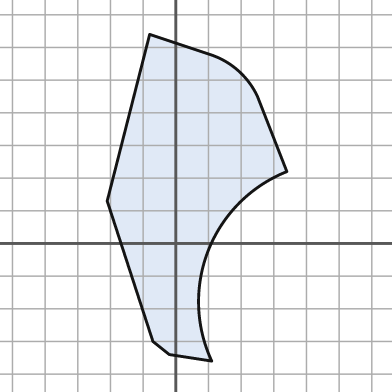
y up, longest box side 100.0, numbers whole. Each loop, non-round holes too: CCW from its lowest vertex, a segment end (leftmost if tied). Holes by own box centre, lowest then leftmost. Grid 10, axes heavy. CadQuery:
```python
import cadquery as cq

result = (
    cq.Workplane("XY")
    .moveTo(11.0, -36.0)
    .threePointArc((10.0, -2.0), (34.0, 22.0))
    .lineTo(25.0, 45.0)
    .threePointArc((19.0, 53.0), (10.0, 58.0))
    .lineTo(-8.0, 64.0)
    .lineTo(-21.0, 13.0)
    .lineTo(-7.0, -30.0)
    .lineTo(-2.0, -34.0)
    .close()
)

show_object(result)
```